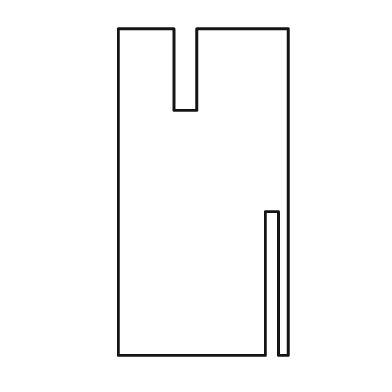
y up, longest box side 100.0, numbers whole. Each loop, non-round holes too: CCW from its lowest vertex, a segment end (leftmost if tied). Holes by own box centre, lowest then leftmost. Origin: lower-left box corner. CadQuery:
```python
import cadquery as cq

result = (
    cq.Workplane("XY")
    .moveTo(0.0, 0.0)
    .lineTo(45.0, 0.0)
    .lineTo(45.0, 44.0)
    .lineTo(49.0, 44.0)
    .lineTo(49.0, 0.0)
    .lineTo(52.0, 0.0)
    .lineTo(52.0, 100.0)
    .lineTo(24.0, 100.0)
    .lineTo(24.0, 75.0)
    .lineTo(17.0, 75.0)
    .lineTo(17.0, 100.0)
    .lineTo(0.0, 100.0)
    .close()
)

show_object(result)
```